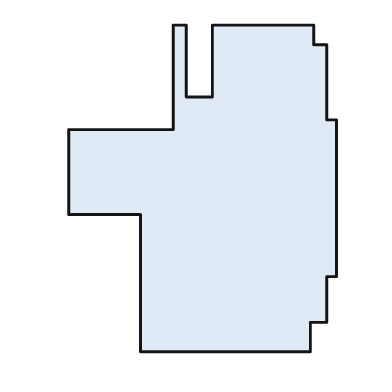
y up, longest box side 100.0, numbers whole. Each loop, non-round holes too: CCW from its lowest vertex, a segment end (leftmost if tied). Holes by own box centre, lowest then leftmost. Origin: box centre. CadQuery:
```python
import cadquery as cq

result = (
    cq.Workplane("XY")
    .moveTo(-19.0, -50.0)
    .lineTo(33.0, -50.0)
    .lineTo(33.0, -41.0)
    .lineTo(38.0, -41.0)
    .lineTo(38.0, -27.0)
    .lineTo(41.0, -27.0)
    .lineTo(41.0, 21.0)
    .lineTo(38.0, 21.0)
    .lineTo(38.0, 44.0)
    .lineTo(34.0, 44.0)
    .lineTo(34.0, 50.0)
    .lineTo(3.0, 50.0)
    .lineTo(3.0, 28.0)
    .lineTo(-5.0, 28.0)
    .lineTo(-5.0, 50.0)
    .lineTo(-9.0, 50.0)
    .lineTo(-9.0, 18.0)
    .lineTo(-41.0, 18.0)
    .lineTo(-41.0, -8.0)
    .lineTo(-19.0, -8.0)
    .close()
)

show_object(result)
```